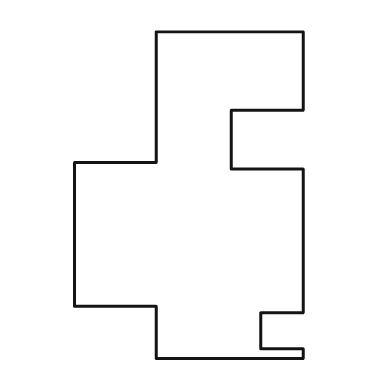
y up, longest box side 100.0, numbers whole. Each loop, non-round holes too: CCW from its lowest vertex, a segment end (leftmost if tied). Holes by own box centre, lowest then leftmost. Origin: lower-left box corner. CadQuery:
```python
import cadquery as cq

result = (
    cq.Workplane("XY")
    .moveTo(25.0, 0.0)
    .lineTo(70.0, 0.0)
    .lineTo(70.0, 3.0)
    .lineTo(57.0, 3.0)
    .lineTo(57.0, 14.0)
    .lineTo(70.0, 14.0)
    .lineTo(70.0, 58.0)
    .lineTo(48.0, 58.0)
    .lineTo(48.0, 76.0)
    .lineTo(70.0, 76.0)
    .lineTo(70.0, 100.0)
    .lineTo(25.0, 100.0)
    .lineTo(25.0, 60.0)
    .lineTo(0.0, 60.0)
    .lineTo(0.0, 16.0)
    .lineTo(25.0, 16.0)
    .close()
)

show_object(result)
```